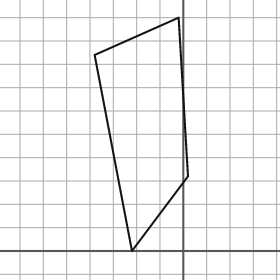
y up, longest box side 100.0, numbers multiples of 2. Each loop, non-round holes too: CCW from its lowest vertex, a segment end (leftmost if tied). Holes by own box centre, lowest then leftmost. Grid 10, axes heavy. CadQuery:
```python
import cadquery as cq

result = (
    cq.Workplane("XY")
    .moveTo(-22.0, 0.0)
    .lineTo(2.0, 32.0)
    .lineTo(-2.0, 100.0)
    .lineTo(-38.0, 84.0)
    .close()
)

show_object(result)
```